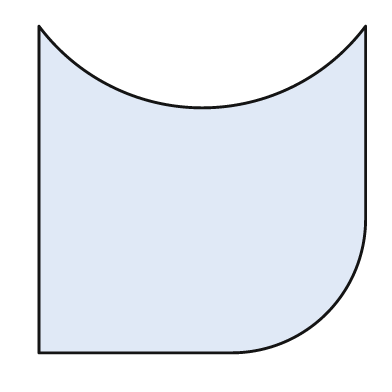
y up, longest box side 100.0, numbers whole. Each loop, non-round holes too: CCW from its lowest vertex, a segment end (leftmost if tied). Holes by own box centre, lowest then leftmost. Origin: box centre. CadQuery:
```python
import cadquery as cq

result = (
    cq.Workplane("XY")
    .moveTo(-50.0, -50.0)
    .lineTo(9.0, -50.0)
    .threePointArc((38.0, -38.0), (50.0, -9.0))
    .lineTo(50.0, 50.0)
    .threePointArc((0.0, 25.0), (-50.0, 50.0))
    .close()
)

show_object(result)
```